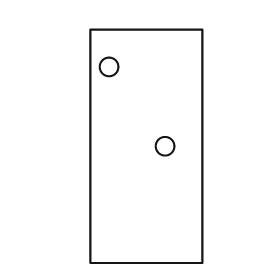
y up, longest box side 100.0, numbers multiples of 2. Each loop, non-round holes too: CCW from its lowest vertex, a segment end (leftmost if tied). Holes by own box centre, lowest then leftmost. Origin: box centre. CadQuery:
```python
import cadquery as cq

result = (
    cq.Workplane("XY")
    .moveTo(-24.0, -50.0)
    .lineTo(24.0, -50.0)
    .lineTo(24.0, 50.0)
    .lineTo(-24.0, 50.0)
    .close()
    .moveTo(8.0, 0.0)
    .circle(4.0)
    .moveTo(-16.0, 34.0)
    .circle(4.0)
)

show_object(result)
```